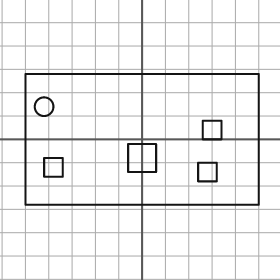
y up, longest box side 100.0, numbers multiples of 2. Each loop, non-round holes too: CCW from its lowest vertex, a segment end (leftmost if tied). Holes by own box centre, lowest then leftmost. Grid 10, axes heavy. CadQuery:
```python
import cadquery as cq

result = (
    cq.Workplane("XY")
    .moveTo(-50.0, -28.0)
    .lineTo(50.0, -28.0)
    .lineTo(50.0, 28.0)
    .lineTo(-50.0, 28.0)
    .close()
    .moveTo(24.0, -18.0)
    .lineTo(32.0, -18.0)
    .lineTo(32.0, -10.0)
    .lineTo(24.0, -10.0)
    .close()
    .moveTo(-42.0, -16.0)
    .lineTo(-34.0, -16.0)
    .lineTo(-34.0, -8.0)
    .lineTo(-42.0, -8.0)
    .close()
    .moveTo(-6.0, -14.0)
    .lineTo(6.0, -14.0)
    .lineTo(6.0, -2.0)
    .lineTo(-6.0, -2.0)
    .close()
    .moveTo(26.0, 0.0)
    .lineTo(34.0, 0.0)
    .lineTo(34.0, 8.0)
    .lineTo(26.0, 8.0)
    .close()
    .moveTo(-42.0, 14.0)
    .circle(4.0)
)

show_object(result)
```